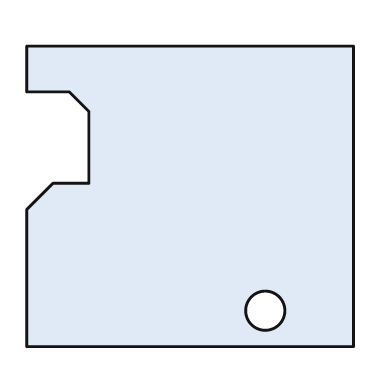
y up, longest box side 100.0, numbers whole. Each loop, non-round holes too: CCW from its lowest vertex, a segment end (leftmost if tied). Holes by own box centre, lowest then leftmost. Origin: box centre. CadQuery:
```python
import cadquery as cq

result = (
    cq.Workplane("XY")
    .moveTo(-50.0, -46.0)
    .lineTo(50.0, -46.0)
    .lineTo(50.0, 46.0)
    .lineTo(-50.0, 46.0)
    .lineTo(-50.0, 32.0)
    .lineTo(-37.0, 32.0)
    .lineTo(-31.0, 26.0)
    .lineTo(-31.0, 4.0)
    .lineTo(-42.0, 4.0)
    .lineTo(-50.0, -4.0)
    .close()
    .moveTo(23.0, -35.0)
    .circle(6.0)
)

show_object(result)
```